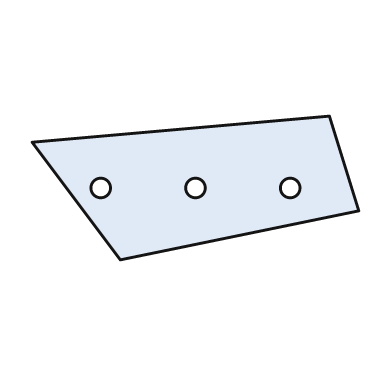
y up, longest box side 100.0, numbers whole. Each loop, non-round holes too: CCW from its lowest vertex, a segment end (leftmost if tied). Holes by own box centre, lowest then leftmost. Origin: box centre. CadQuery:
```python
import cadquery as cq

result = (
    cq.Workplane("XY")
    .moveTo(-23.0, -22.0)
    .lineTo(50.0, -7.0)
    .lineTo(41.0, 22.0)
    .lineTo(-50.0, 14.0)
    .close()
    .moveTo(-29.0, 0.0)
    .circle(3.0)
    .moveTo(0.0, 0.0)
    .circle(3.0)
    .moveTo(29.0, 0.0)
    .circle(3.0)
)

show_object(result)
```